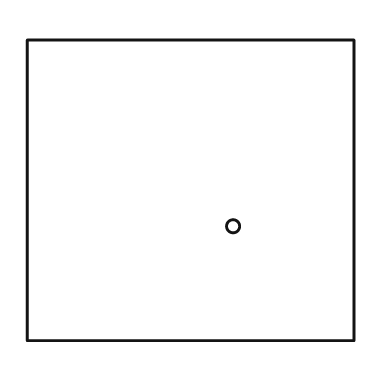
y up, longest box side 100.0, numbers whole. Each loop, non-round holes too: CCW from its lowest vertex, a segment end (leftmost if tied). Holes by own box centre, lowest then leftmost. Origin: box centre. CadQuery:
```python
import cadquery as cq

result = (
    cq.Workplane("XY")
    .moveTo(-50.0, -46.0)
    .lineTo(50.0, -46.0)
    .lineTo(50.0, 46.0)
    .lineTo(-50.0, 46.0)
    .close()
    .moveTo(13.0, -11.0)
    .circle(2.0)
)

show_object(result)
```